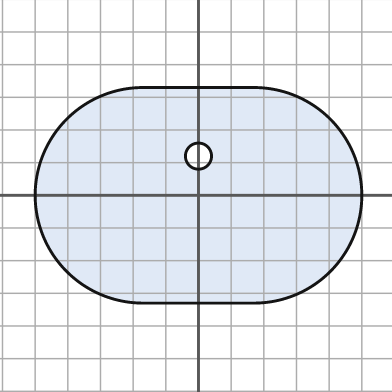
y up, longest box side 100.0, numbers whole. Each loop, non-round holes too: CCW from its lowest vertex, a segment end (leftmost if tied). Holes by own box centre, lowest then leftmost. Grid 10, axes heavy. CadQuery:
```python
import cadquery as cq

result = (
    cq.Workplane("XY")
    .moveTo(-17.0, -33.0)
    .lineTo(17.0, -33.0)
    .threePointArc((50.0, 0.0), (17.0, 33.0))
    .lineTo(-17.0, 33.0)
    .threePointArc((-50.0, 0.0), (-17.0, -33.0))
    .close()
    .moveTo(0.0, 12.0)
    .circle(4.0)
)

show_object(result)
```